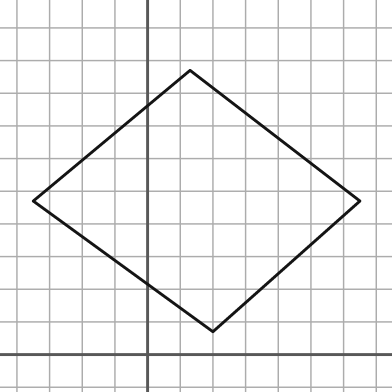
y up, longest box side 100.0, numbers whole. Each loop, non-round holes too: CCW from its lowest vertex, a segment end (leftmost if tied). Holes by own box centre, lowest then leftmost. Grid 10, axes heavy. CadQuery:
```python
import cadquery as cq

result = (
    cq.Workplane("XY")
    .moveTo(20.0, 7.0)
    .lineTo(65.0, 47.0)
    .lineTo(13.0, 87.0)
    .lineTo(-35.0, 47.0)
    .close()
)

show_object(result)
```